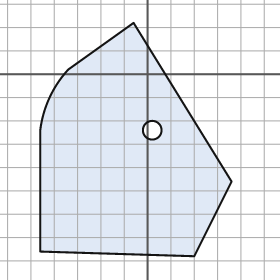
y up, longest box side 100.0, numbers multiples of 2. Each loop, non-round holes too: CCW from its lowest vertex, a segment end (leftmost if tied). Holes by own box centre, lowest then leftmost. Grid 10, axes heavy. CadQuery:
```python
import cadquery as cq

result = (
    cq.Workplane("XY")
    .moveTo(20.0, -78.0)
    .lineTo(36.0, -46.0)
    .lineTo(-6.0, 22.0)
    .lineTo(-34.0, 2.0)
    .threePointArc((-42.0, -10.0), (-46.0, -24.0))
    .lineTo(-46.0, -76.0)
    .close()
    .moveTo(2.0, -24.0)
    .circle(4.0)
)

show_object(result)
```